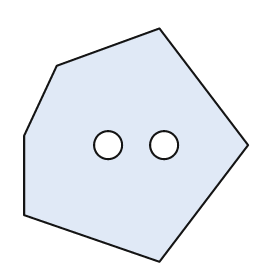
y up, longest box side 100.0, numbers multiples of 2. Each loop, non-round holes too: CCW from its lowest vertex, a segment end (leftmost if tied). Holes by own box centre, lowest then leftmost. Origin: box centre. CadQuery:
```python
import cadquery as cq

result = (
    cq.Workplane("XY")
    .moveTo(10.0, -50.0)
    .lineTo(48.0, 0.0)
    .lineTo(10.0, 50.0)
    .lineTo(-34.0, 34.0)
    .lineTo(-48.0, 4.0)
    .lineTo(-48.0, -30.0)
    .close()
    .moveTo(-12.0, 0.0)
    .circle(6.0)
    .moveTo(12.0, 0.0)
    .circle(6.0)
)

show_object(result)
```